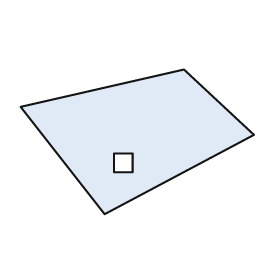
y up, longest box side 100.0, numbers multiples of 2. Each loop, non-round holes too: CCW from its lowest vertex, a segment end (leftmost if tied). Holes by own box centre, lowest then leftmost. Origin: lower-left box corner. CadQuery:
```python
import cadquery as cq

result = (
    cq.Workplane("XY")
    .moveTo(36.0, 0.0)
    .lineTo(100.0, 34.0)
    .lineTo(70.0, 62.0)
    .lineTo(0.0, 46.0)
    .close()
    .moveTo(40.0, 18.0)
    .lineTo(48.0, 18.0)
    .lineTo(48.0, 26.0)
    .lineTo(40.0, 26.0)
    .close()
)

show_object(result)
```